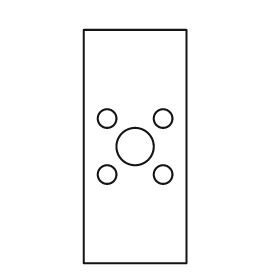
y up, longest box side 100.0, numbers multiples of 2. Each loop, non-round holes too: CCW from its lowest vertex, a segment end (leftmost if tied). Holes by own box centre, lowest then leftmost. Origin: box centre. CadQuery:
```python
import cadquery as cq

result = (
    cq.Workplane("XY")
    .moveTo(-22.0, -50.0)
    .lineTo(22.0, -50.0)
    .lineTo(22.0, 50.0)
    .lineTo(-22.0, 50.0)
    .close()
    .moveTo(-12.0, -12.0)
    .circle(4.0)
    .moveTo(12.0, -12.0)
    .circle(4.0)
    .moveTo(0.0, 0.0)
    .circle(8.0)
    .moveTo(-12.0, 12.0)
    .circle(4.0)
    .moveTo(12.0, 12.0)
    .circle(4.0)
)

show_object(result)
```